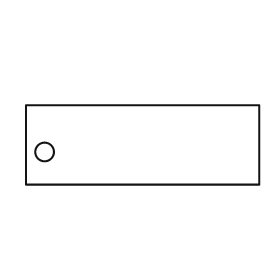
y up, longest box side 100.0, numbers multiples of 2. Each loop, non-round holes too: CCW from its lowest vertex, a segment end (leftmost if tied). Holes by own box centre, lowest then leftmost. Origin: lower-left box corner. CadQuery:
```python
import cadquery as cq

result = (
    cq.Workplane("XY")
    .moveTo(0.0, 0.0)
    .lineTo(100.0, 0.0)
    .lineTo(100.0, 34.0)
    .lineTo(0.0, 34.0)
    .close()
    .moveTo(8.0, 14.0)
    .circle(4.0)
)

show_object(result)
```